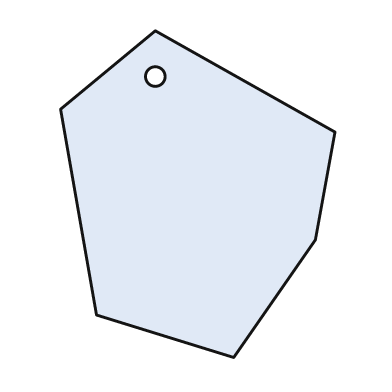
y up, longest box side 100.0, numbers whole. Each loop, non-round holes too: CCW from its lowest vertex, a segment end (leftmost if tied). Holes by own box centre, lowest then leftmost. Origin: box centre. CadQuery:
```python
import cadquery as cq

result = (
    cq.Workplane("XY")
    .moveTo(11.0, -50.0)
    .lineTo(36.0, -14.0)
    .lineTo(42.0, 19.0)
    .lineTo(-13.0, 50.0)
    .lineTo(-42.0, 26.0)
    .lineTo(-31.0, -37.0)
    .close()
    .moveTo(-13.0, 36.0)
    .circle(3.0)
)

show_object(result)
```